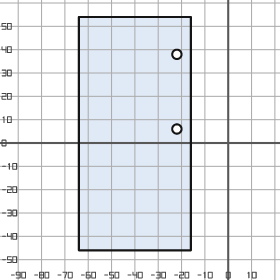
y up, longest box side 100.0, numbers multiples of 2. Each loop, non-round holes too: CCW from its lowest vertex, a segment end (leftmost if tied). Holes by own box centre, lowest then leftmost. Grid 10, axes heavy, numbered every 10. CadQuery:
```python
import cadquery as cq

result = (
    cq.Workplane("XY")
    .moveTo(-64.0, -46.0)
    .lineTo(-16.0, -46.0)
    .lineTo(-16.0, 54.0)
    .lineTo(-64.0, 54.0)
    .close()
    .moveTo(-22.0, 6.0)
    .circle(2.0)
    .moveTo(-22.0, 38.0)
    .circle(2.0)
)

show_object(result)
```